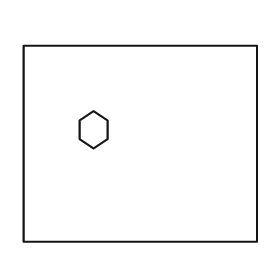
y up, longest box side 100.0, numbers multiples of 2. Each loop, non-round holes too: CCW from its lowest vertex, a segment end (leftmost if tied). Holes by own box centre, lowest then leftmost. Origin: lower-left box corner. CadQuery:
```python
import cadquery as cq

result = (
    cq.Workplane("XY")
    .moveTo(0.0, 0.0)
    .lineTo(100.0, 0.0)
    .lineTo(100.0, 84.0)
    .lineTo(0.0, 84.0)
    .close()
    .moveTo(30.0, 40.0)
    .lineTo(36.0, 44.0)
    .lineTo(36.0, 52.0)
    .lineTo(30.0, 56.0)
    .lineTo(24.0, 52.0)
    .lineTo(24.0, 44.0)
    .close()
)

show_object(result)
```